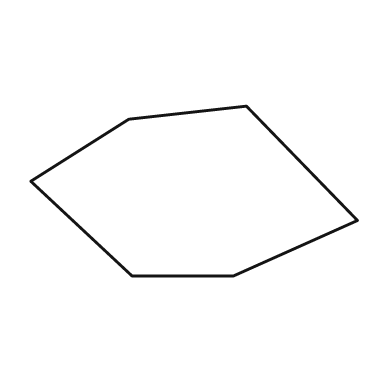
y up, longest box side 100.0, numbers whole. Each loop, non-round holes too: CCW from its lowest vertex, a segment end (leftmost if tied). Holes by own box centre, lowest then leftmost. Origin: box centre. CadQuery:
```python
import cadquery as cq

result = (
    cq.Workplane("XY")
    .moveTo(-19.0, -26.0)
    .lineTo(12.0, -26.0)
    .lineTo(50.0, -9.0)
    .lineTo(16.0, 26.0)
    .lineTo(-20.0, 22.0)
    .lineTo(-50.0, 3.0)
    .close()
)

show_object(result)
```